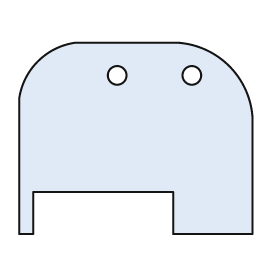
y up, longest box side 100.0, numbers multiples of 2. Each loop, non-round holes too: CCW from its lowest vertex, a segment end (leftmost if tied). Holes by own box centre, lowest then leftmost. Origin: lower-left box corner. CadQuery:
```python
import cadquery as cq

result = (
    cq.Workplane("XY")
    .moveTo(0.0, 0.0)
    .lineTo(6.0, 0.0)
    .lineTo(6.0, 18.0)
    .lineTo(66.0, 18.0)
    .lineTo(66.0, 0.0)
    .lineTo(100.0, 0.0)
    .lineTo(100.0, 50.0)
    .threePointArc((90.0, 72.0), (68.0, 82.0))
    .lineTo(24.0, 82.0)
    .threePointArc((8.0, 74.0), (0.0, 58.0))
    .close()
    .moveTo(42.0, 68.0)
    .circle(4.0)
    .moveTo(74.0, 68.0)
    .circle(4.0)
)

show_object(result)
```